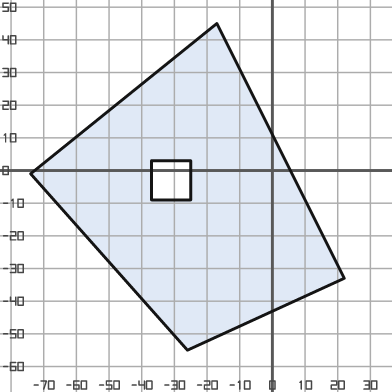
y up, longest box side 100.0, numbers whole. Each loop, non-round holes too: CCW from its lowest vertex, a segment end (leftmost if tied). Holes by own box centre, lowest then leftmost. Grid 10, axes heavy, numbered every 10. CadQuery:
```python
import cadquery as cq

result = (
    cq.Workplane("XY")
    .moveTo(-26.0, -55.0)
    .lineTo(22.0, -33.0)
    .lineTo(-17.0, 45.0)
    .lineTo(-74.0, -1.0)
    .close()
    .moveTo(-37.0, -9.0)
    .lineTo(-25.0, -9.0)
    .lineTo(-25.0, 3.0)
    .lineTo(-37.0, 3.0)
    .close()
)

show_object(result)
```